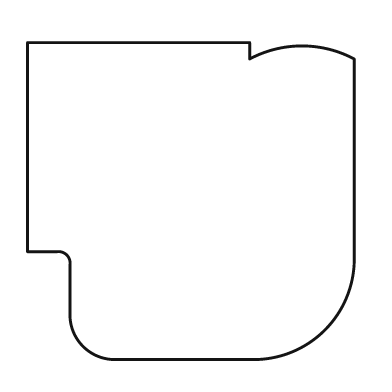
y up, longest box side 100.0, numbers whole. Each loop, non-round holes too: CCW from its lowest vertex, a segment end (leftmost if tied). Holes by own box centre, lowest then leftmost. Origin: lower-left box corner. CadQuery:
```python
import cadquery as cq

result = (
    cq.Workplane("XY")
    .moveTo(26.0, 0.0)
    .lineTo(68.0, 0.0)
    .threePointArc((91.0, 9.0), (100.0, 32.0))
    .lineTo(100.0, 92.0)
    .threePointArc((84.0, 96.0), (68.0, 92.0))
    .lineTo(68.0, 97.0)
    .lineTo(0.0, 97.0)
    .lineTo(0.0, 33.0)
    .lineTo(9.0, 33.0)
    .threePointArc((12.0, 32.0), (13.0, 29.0))
    .lineTo(13.0, 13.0)
    .threePointArc((17.0, 4.0), (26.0, 0.0))
    .close()
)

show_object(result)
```